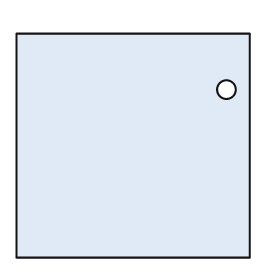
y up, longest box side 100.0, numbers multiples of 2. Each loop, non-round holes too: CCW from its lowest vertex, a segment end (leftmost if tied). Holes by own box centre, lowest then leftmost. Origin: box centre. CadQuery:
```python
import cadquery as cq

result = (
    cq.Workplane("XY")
    .moveTo(-50.0, -48.0)
    .lineTo(50.0, -48.0)
    .lineTo(50.0, 48.0)
    .lineTo(-50.0, 48.0)
    .close()
    .moveTo(40.0, 24.0)
    .circle(4.0)
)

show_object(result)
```